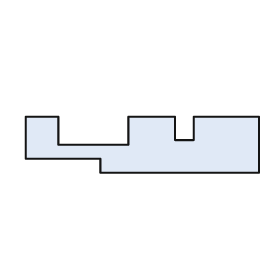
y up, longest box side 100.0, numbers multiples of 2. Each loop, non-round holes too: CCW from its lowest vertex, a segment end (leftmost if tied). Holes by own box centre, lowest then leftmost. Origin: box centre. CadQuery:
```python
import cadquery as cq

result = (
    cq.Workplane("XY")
    .moveTo(-18.0, -12.0)
    .lineTo(50.0, -12.0)
    .lineTo(50.0, 12.0)
    .lineTo(22.0, 12.0)
    .lineTo(22.0, 2.0)
    .lineTo(14.0, 2.0)
    .lineTo(14.0, 12.0)
    .lineTo(-6.0, 12.0)
    .lineTo(-6.0, 0.0)
    .lineTo(-36.0, 0.0)
    .lineTo(-36.0, 12.0)
    .lineTo(-50.0, 12.0)
    .lineTo(-50.0, -6.0)
    .lineTo(-18.0, -6.0)
    .close()
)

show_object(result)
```